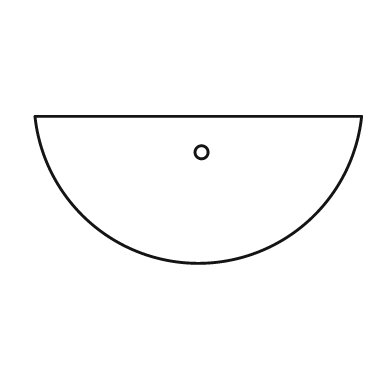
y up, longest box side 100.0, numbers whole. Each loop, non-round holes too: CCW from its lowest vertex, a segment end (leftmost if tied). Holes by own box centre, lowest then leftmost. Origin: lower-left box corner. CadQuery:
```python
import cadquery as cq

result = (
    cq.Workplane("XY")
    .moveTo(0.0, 45.0)
    .threePointArc((50.0, 0.0), (100.0, 45.0))
    .close()
    .moveTo(51.0, 34.0)
    .circle(2.0)
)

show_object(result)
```